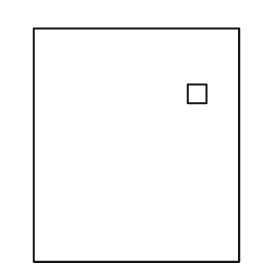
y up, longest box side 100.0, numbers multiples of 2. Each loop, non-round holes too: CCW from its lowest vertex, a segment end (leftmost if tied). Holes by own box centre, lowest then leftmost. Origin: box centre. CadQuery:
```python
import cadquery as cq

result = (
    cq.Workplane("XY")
    .moveTo(-44.0, -50.0)
    .lineTo(44.0, -50.0)
    .lineTo(44.0, 50.0)
    .lineTo(-44.0, 50.0)
    .close()
    .moveTo(22.0, 18.0)
    .lineTo(30.0, 18.0)
    .lineTo(30.0, 26.0)
    .lineTo(22.0, 26.0)
    .close()
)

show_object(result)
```